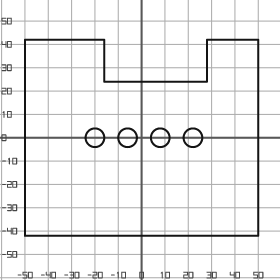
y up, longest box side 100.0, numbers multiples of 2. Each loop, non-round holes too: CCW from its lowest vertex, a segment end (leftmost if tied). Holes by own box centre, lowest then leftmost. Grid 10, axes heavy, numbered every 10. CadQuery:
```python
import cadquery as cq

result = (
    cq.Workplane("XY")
    .moveTo(-50.0, -42.0)
    .lineTo(50.0, -42.0)
    .lineTo(50.0, 42.0)
    .lineTo(28.0, 42.0)
    .lineTo(28.0, 24.0)
    .lineTo(-16.0, 24.0)
    .lineTo(-16.0, 42.0)
    .lineTo(-50.0, 42.0)
    .close()
    .moveTo(-20.0, 0.0)
    .circle(4.0)
    .moveTo(-6.0, 0.0)
    .circle(4.0)
    .moveTo(8.0, 0.0)
    .circle(4.0)
    .moveTo(22.0, 0.0)
    .circle(4.0)
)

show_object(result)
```